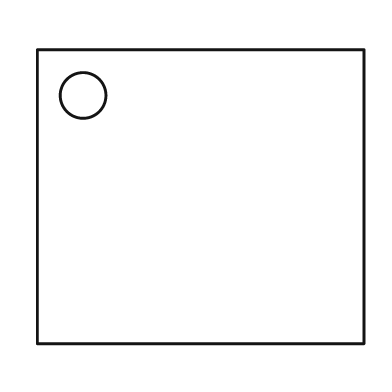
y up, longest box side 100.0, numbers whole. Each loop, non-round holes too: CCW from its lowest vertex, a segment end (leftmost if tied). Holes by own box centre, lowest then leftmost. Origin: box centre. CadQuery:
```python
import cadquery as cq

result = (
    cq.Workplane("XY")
    .moveTo(-50.0, -45.0)
    .lineTo(50.0, -45.0)
    .lineTo(50.0, 45.0)
    .lineTo(-50.0, 45.0)
    .close()
    .moveTo(-36.0, 31.0)
    .circle(7.0)
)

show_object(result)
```